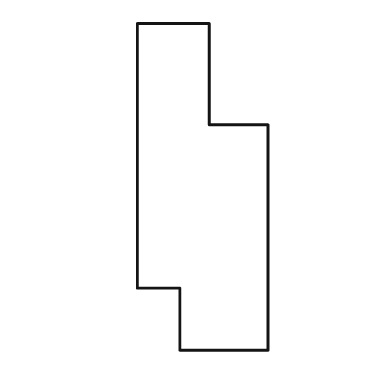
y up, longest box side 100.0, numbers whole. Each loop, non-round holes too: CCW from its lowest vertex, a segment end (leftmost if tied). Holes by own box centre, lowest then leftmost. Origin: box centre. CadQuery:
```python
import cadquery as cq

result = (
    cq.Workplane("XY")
    .moveTo(-7.0, -50.0)
    .lineTo(20.0, -50.0)
    .lineTo(20.0, 19.0)
    .lineTo(2.0, 19.0)
    .lineTo(2.0, 50.0)
    .lineTo(-20.0, 50.0)
    .lineTo(-20.0, -31.0)
    .lineTo(-7.0, -31.0)
    .close()
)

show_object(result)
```